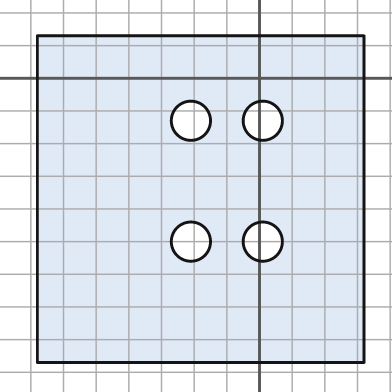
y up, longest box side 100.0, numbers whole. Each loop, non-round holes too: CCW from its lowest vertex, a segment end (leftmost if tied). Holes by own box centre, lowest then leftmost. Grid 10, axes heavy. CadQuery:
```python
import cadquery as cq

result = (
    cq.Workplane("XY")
    .moveTo(-68.0, -87.0)
    .lineTo(32.0, -87.0)
    .lineTo(32.0, 13.0)
    .lineTo(-68.0, 13.0)
    .close()
    .moveTo(-21.0, -50.0)
    .circle(6.0)
    .moveTo(1.0, -50.0)
    .circle(6.0)
    .moveTo(-21.0, -13.0)
    .circle(6.0)
    .moveTo(1.0, -13.0)
    .circle(6.0)
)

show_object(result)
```